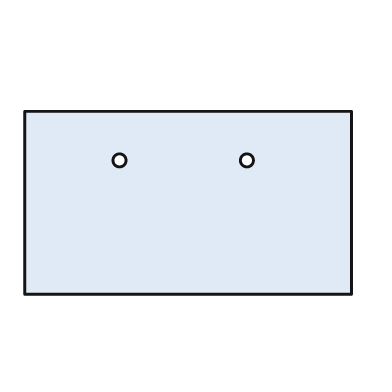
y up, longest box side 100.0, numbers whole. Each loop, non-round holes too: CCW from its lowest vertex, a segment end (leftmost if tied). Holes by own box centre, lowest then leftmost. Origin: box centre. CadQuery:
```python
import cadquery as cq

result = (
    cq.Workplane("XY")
    .moveTo(-50.0, -28.0)
    .lineTo(50.0, -28.0)
    .lineTo(50.0, 28.0)
    .lineTo(-50.0, 28.0)
    .close()
    .moveTo(-21.0, 13.0)
    .circle(2.0)
    .moveTo(18.0, 13.0)
    .circle(2.0)
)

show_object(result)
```